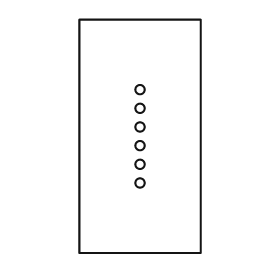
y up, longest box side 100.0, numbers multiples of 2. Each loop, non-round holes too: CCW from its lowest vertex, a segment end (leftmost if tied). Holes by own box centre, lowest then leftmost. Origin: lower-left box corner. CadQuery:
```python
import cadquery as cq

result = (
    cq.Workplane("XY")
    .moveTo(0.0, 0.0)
    .lineTo(52.0, 0.0)
    .lineTo(52.0, 100.0)
    .lineTo(0.0, 100.0)
    .close()
    .moveTo(26.0, 30.0)
    .circle(2.0)
    .moveTo(26.0, 38.0)
    .circle(2.0)
    .moveTo(26.0, 46.0)
    .circle(2.0)
    .moveTo(26.0, 54.0)
    .circle(2.0)
    .moveTo(26.0, 62.0)
    .circle(2.0)
    .moveTo(26.0, 70.0)
    .circle(2.0)
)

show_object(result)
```